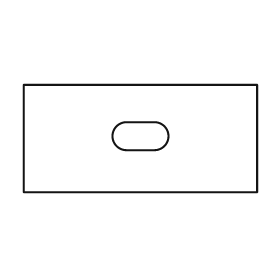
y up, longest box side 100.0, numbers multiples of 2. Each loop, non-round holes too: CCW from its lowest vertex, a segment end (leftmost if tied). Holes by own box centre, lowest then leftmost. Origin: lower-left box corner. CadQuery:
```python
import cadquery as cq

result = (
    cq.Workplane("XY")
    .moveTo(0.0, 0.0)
    .lineTo(100.0, 0.0)
    .lineTo(100.0, 46.0)
    .lineTo(0.0, 46.0)
    .close()
    .moveTo(44.0, 18.0)
    .lineTo(56.0, 18.0)
    .threePointArc((62.0, 24.0), (56.0, 30.0))
    .lineTo(44.0, 30.0)
    .threePointArc((38.0, 24.0), (44.0, 18.0))
    .close()
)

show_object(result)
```